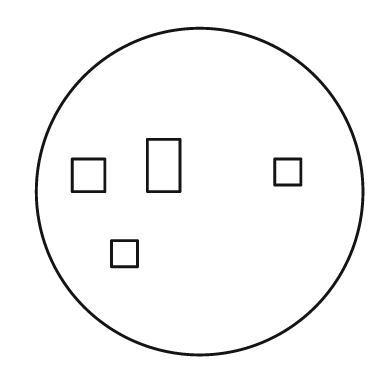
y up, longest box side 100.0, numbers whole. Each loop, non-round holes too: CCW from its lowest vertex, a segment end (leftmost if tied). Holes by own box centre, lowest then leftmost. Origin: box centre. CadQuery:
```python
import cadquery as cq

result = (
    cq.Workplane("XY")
    .moveTo(0.0, 0.0)
    .circle(50.0)
    .moveTo(-27.0, -23.0)
    .lineTo(-19.0, -23.0)
    .lineTo(-19.0, -15.0)
    .lineTo(-27.0, -15.0)
    .close()
    .moveTo(-39.0, 0.0)
    .lineTo(-29.0, 0.0)
    .lineTo(-29.0, 10.0)
    .lineTo(-39.0, 10.0)
    .close()
    .moveTo(23.0, 2.0)
    .lineTo(31.0, 2.0)
    .lineTo(31.0, 10.0)
    .lineTo(23.0, 10.0)
    .close()
    .moveTo(-16.0, 0.0)
    .lineTo(-6.0, 0.0)
    .lineTo(-6.0, 16.0)
    .lineTo(-16.0, 16.0)
    .close()
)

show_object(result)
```